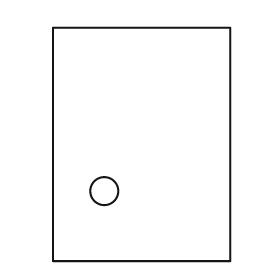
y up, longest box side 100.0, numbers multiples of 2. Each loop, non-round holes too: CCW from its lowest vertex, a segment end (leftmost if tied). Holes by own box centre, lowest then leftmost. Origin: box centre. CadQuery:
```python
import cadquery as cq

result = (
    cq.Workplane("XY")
    .moveTo(-38.0, -50.0)
    .lineTo(38.0, -50.0)
    .lineTo(38.0, 50.0)
    .lineTo(-38.0, 50.0)
    .close()
    .moveTo(-16.0, -20.0)
    .circle(6.0)
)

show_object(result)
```